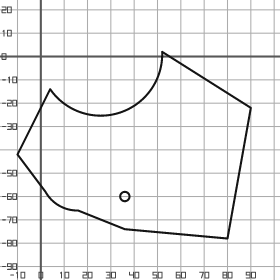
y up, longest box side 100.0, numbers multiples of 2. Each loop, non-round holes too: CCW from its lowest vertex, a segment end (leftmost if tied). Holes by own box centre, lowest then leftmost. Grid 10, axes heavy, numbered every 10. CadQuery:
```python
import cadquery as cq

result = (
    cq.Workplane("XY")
    .moveTo(80.0, -78.0)
    .lineTo(90.0, -22.0)
    .lineTo(52.0, 2.0)
    .threePointArc((34.0, -24.0), (4.0, -14.0))
    .lineTo(-10.0, -42.0)
    .lineTo(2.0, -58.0)
    .threePointArc((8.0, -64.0), (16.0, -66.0))
    .lineTo(36.0, -74.0)
    .close()
    .moveTo(36.0, -60.0)
    .circle(2.0)
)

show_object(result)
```